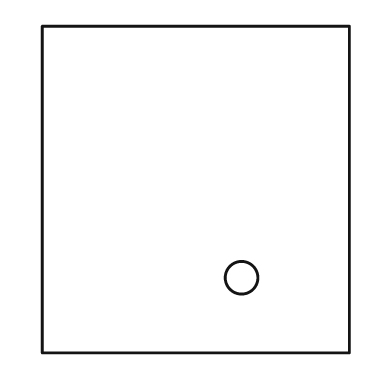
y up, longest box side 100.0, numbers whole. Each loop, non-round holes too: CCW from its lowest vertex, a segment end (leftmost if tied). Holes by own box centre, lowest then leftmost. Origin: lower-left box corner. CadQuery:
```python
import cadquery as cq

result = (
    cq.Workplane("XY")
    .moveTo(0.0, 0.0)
    .lineTo(94.0, 0.0)
    .lineTo(94.0, 100.0)
    .lineTo(0.0, 100.0)
    .close()
    .moveTo(61.0, 23.0)
    .circle(5.0)
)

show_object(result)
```